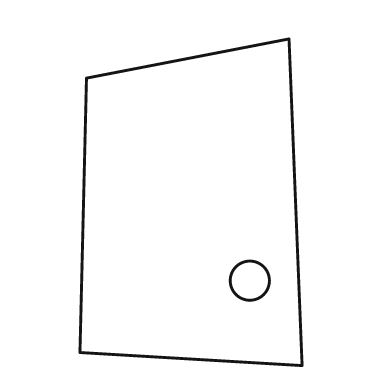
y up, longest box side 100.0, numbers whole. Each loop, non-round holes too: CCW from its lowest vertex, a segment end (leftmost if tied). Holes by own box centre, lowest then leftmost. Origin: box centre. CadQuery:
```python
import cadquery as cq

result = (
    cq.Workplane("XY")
    .moveTo(34.0, -50.0)
    .lineTo(30.0, 50.0)
    .lineTo(-32.0, 38.0)
    .lineTo(-34.0, -46.0)
    .close()
    .moveTo(18.0, -24.0)
    .circle(6.0)
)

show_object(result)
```